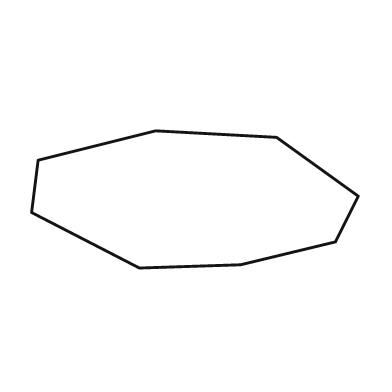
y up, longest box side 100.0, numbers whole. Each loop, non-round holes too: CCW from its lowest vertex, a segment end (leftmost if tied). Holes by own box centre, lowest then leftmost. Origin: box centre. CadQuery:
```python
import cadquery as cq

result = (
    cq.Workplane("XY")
    .moveTo(-17.0, -21.0)
    .lineTo(14.0, -20.0)
    .lineTo(43.0, -13.0)
    .lineTo(50.0, 1.0)
    .lineTo(25.0, 19.0)
    .lineTo(-12.0, 21.0)
    .lineTo(-48.0, 12.0)
    .lineTo(-50.0, -4.0)
    .close()
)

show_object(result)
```